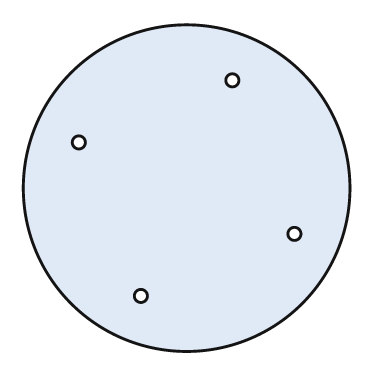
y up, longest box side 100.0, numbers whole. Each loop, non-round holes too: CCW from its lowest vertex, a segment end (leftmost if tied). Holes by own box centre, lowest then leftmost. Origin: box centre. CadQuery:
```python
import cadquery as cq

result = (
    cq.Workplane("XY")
    .moveTo(0.0, 0.0)
    .circle(50.0)
    .moveTo(-14.0, -33.0)
    .circle(2.0)
    .moveTo(33.0, -14.0)
    .circle(2.0)
    .moveTo(-33.0, 14.0)
    .circle(2.0)
    .moveTo(14.0, 33.0)
    .circle(2.0)
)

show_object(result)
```